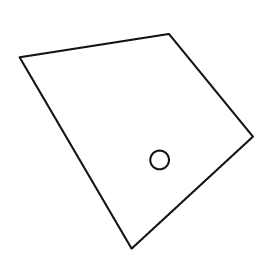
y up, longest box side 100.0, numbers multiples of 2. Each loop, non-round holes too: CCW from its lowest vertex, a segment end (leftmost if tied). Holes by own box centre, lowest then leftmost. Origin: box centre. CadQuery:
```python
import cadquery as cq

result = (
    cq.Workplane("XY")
    .moveTo(-2.0, -46.0)
    .lineTo(50.0, 2.0)
    .lineTo(14.0, 46.0)
    .lineTo(-50.0, 36.0)
    .close()
    .moveTo(10.0, -8.0)
    .circle(4.0)
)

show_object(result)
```